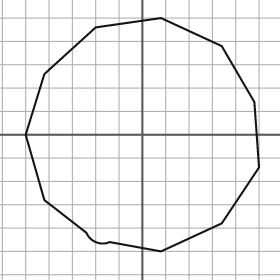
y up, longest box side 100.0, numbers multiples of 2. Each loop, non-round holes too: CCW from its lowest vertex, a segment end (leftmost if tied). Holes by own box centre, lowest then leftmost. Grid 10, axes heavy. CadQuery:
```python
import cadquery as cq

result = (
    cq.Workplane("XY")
    .moveTo(8.0, -50.0)
    .lineTo(34.0, -38.0)
    .lineTo(50.0, -14.0)
    .lineTo(48.0, 14.0)
    .lineTo(34.0, 38.0)
    .lineTo(8.0, 50.0)
    .lineTo(-20.0, 46.0)
    .lineTo(-42.0, 26.0)
    .lineTo(-50.0, 0.0)
    .lineTo(-42.0, -28.0)
    .lineTo(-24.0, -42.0)
    .threePointArc((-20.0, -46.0), (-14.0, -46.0))
    .close()
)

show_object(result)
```